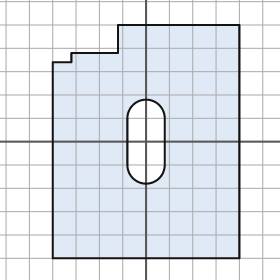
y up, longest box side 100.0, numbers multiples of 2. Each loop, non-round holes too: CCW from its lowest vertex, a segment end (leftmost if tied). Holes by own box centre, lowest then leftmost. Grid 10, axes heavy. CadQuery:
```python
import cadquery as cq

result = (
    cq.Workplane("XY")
    .moveTo(-40.0, -50.0)
    .lineTo(40.0, -50.0)
    .lineTo(40.0, 50.0)
    .lineTo(-12.0, 50.0)
    .lineTo(-12.0, 38.0)
    .lineTo(-32.0, 38.0)
    .lineTo(-32.0, 34.0)
    .lineTo(-40.0, 34.0)
    .close()
    .moveTo(-8.0, -10.0)
    .threePointArc((0.0, -18.0), (8.0, -10.0))
    .lineTo(8.0, 10.0)
    .threePointArc((0.0, 18.0), (-8.0, 10.0))
    .close()
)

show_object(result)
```